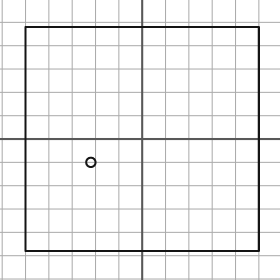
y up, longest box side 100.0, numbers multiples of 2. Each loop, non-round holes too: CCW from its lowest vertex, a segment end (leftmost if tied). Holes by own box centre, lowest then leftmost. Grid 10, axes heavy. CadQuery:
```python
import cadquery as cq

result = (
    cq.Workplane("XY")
    .moveTo(-50.0, -48.0)
    .lineTo(50.0, -48.0)
    .lineTo(50.0, 48.0)
    .lineTo(-50.0, 48.0)
    .close()
    .moveTo(-22.0, -10.0)
    .circle(2.0)
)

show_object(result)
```